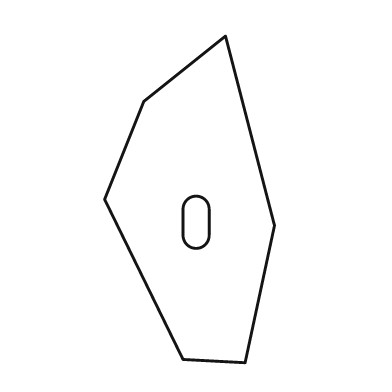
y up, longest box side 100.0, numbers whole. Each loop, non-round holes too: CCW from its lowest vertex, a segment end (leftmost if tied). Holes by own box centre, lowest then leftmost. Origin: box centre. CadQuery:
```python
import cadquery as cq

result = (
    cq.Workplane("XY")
    .moveTo(17.0, -50.0)
    .lineTo(26.0, -8.0)
    .lineTo(11.0, 50.0)
    .lineTo(-14.0, 30.0)
    .lineTo(-26.0, 0.0)
    .lineTo(-2.0, -49.0)
    .close()
    .moveTo(-2.0, -11.0)
    .threePointArc((2.0, -15.0), (6.0, -11.0))
    .lineTo(6.0, -3.0)
    .threePointArc((2.0, 1.0), (-2.0, -3.0))
    .close()
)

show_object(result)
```